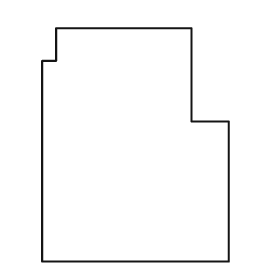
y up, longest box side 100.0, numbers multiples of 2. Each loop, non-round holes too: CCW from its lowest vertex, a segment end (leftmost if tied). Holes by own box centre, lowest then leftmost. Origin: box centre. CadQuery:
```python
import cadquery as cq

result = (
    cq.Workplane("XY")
    .moveTo(-40.0, -50.0)
    .lineTo(40.0, -50.0)
    .lineTo(40.0, 10.0)
    .lineTo(24.0, 10.0)
    .lineTo(24.0, 50.0)
    .lineTo(-34.0, 50.0)
    .lineTo(-34.0, 36.0)
    .lineTo(-40.0, 36.0)
    .close()
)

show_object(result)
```